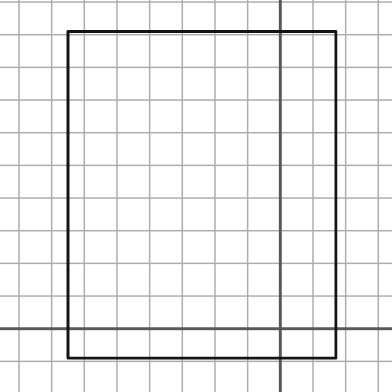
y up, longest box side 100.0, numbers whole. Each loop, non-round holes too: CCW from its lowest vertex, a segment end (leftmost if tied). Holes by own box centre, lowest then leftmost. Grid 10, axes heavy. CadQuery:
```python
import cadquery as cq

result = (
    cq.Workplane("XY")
    .moveTo(-65.0, -9.0)
    .lineTo(17.0, -9.0)
    .lineTo(17.0, 91.0)
    .lineTo(-65.0, 91.0)
    .close()
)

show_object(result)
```